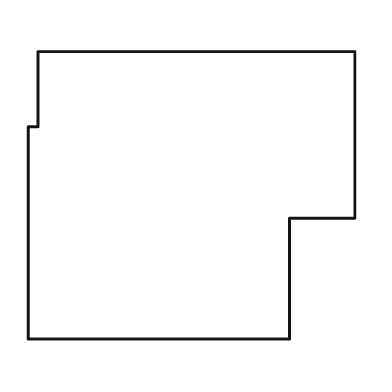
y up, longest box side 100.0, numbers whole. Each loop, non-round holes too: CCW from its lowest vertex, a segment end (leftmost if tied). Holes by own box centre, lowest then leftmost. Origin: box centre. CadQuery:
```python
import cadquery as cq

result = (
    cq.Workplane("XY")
    .moveTo(-50.0, -44.0)
    .lineTo(30.0, -44.0)
    .lineTo(30.0, -7.0)
    .lineTo(50.0, -7.0)
    .lineTo(50.0, 44.0)
    .lineTo(-47.0, 44.0)
    .lineTo(-47.0, 21.0)
    .lineTo(-50.0, 21.0)
    .close()
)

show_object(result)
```